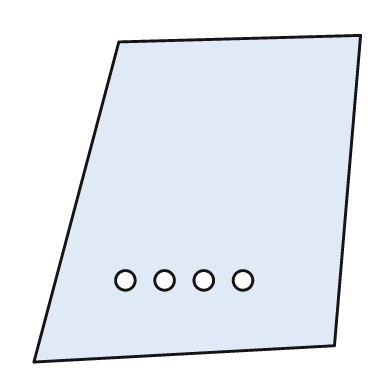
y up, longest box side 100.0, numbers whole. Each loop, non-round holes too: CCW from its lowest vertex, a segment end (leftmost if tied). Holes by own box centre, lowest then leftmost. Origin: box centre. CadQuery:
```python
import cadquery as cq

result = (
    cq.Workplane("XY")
    .moveTo(-50.0, -50.0)
    .lineTo(42.0, -45.0)
    .lineTo(50.0, 50.0)
    .lineTo(-24.0, 48.0)
    .close()
    .moveTo(-22.0, -25.0)
    .circle(3.0)
    .moveTo(-10.0, -25.0)
    .circle(3.0)
    .moveTo(2.0, -25.0)
    .circle(3.0)
    .moveTo(14.0, -25.0)
    .circle(3.0)
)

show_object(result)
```